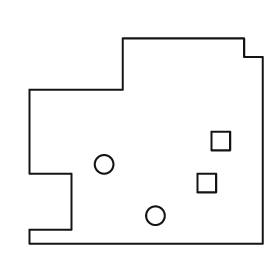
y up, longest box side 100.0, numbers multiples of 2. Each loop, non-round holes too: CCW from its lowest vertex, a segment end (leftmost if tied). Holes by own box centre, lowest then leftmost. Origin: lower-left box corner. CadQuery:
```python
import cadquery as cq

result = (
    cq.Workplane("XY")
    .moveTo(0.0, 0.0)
    .lineTo(100.0, 0.0)
    .lineTo(100.0, 80.0)
    .lineTo(92.0, 80.0)
    .lineTo(92.0, 88.0)
    .lineTo(40.0, 88.0)
    .lineTo(40.0, 66.0)
    .lineTo(0.0, 66.0)
    .lineTo(0.0, 30.0)
    .lineTo(18.0, 30.0)
    .lineTo(18.0, 6.0)
    .lineTo(0.0, 6.0)
    .close()
    .moveTo(54.0, 12.0)
    .circle(4.0)
    .moveTo(72.0, 22.0)
    .lineTo(80.0, 22.0)
    .lineTo(80.0, 30.0)
    .lineTo(72.0, 30.0)
    .close()
    .moveTo(32.0, 34.0)
    .circle(4.0)
    .moveTo(78.0, 40.0)
    .lineTo(86.0, 40.0)
    .lineTo(86.0, 48.0)
    .lineTo(78.0, 48.0)
    .close()
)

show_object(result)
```